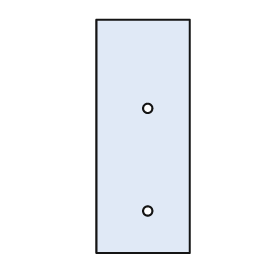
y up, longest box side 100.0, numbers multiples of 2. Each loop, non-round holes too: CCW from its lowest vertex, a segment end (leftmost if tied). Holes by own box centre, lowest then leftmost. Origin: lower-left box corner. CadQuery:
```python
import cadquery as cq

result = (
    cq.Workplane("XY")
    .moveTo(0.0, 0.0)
    .lineTo(40.0, 0.0)
    .lineTo(40.0, 100.0)
    .lineTo(0.0, 100.0)
    .close()
    .moveTo(22.0, 18.0)
    .circle(2.0)
    .moveTo(22.0, 62.0)
    .circle(2.0)
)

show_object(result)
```